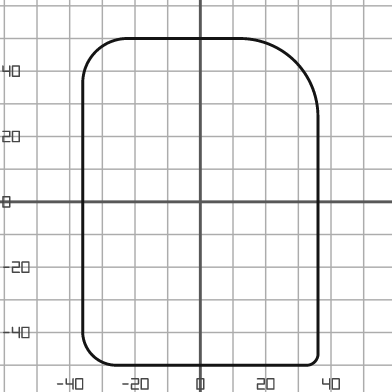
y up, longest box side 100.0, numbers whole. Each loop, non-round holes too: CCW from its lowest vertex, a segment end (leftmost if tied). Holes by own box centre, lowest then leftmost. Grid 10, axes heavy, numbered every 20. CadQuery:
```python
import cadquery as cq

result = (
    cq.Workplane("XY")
    .moveTo(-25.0, -50.0)
    .lineTo(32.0, -50.0)
    .threePointArc((35.0, -49.0), (36.0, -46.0))
    .lineTo(36.0, 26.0)
    .threePointArc((29.0, 43.0), (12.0, 50.0))
    .lineTo(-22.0, 50.0)
    .threePointArc((-32.0, 46.0), (-36.0, 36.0))
    .lineTo(-36.0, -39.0)
    .threePointArc((-33.0, -47.0), (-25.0, -50.0))
    .close()
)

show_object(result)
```